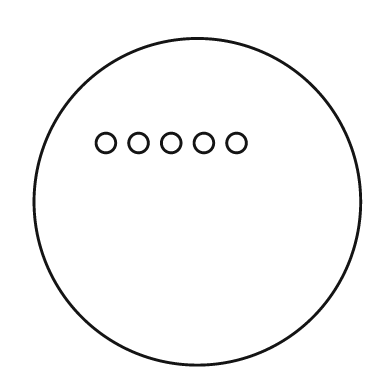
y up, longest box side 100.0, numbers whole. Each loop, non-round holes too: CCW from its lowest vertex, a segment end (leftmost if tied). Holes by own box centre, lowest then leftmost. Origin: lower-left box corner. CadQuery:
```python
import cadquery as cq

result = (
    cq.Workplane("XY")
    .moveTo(50.0, 50.0)
    .circle(50.0)
    .moveTo(22.0, 68.0)
    .circle(3.0)
    .moveTo(32.0, 68.0)
    .circle(3.0)
    .moveTo(42.0, 68.0)
    .circle(3.0)
    .moveTo(52.0, 68.0)
    .circle(3.0)
    .moveTo(62.0, 68.0)
    .circle(3.0)
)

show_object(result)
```